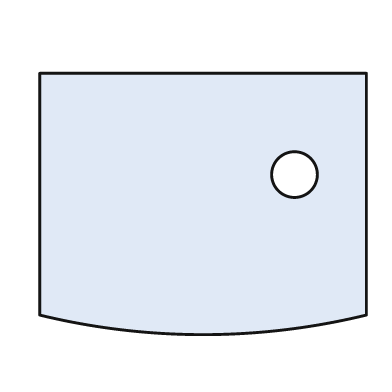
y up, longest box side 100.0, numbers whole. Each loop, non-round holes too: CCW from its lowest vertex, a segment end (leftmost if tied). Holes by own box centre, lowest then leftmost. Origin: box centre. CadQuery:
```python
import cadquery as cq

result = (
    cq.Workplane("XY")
    .moveTo(-50.0, -34.0)
    .threePointArc((0.0, -40.0), (50.0, -34.0))
    .lineTo(50.0, 40.0)
    .lineTo(-50.0, 40.0)
    .close()
    .moveTo(28.0, 9.0)
    .circle(7.0)
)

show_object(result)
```